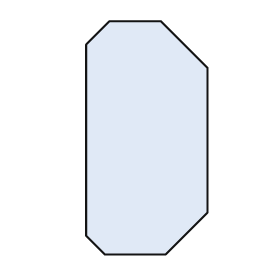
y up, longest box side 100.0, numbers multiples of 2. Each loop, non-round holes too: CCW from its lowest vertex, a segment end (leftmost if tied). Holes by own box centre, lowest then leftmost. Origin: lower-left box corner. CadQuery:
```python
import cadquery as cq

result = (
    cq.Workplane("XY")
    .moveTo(8.0, 0.0)
    .lineTo(34.0, 0.0)
    .lineTo(52.0, 18.0)
    .lineTo(52.0, 80.0)
    .lineTo(32.0, 100.0)
    .lineTo(10.0, 100.0)
    .lineTo(0.0, 90.0)
    .lineTo(0.0, 8.0)
    .close()
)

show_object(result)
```